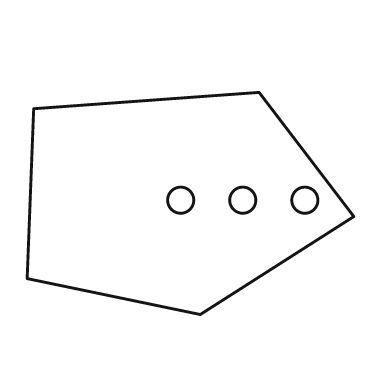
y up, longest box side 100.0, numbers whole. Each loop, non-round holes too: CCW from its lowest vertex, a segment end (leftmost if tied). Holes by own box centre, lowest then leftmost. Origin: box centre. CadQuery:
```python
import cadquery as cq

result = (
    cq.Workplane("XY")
    .moveTo(3.0, -34.0)
    .lineTo(50.0, -4.0)
    .lineTo(21.0, 34.0)
    .lineTo(-48.0, 29.0)
    .lineTo(-50.0, -23.0)
    .close()
    .moveTo(-3.0, 1.0)
    .circle(4.0)
    .moveTo(16.0, 1.0)
    .circle(4.0)
    .moveTo(35.0, 1.0)
    .circle(4.0)
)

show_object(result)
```